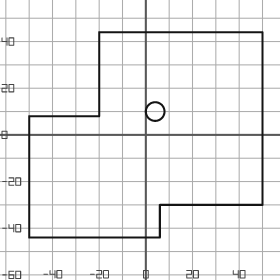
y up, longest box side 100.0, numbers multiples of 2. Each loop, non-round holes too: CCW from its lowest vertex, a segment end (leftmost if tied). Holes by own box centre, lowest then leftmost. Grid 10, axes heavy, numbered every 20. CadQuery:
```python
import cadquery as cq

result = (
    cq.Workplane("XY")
    .moveTo(-50.0, -44.0)
    .lineTo(6.0, -44.0)
    .lineTo(6.0, -30.0)
    .lineTo(50.0, -30.0)
    .lineTo(50.0, 44.0)
    .lineTo(-20.0, 44.0)
    .lineTo(-20.0, 8.0)
    .lineTo(-50.0, 8.0)
    .close()
    .moveTo(4.0, 10.0)
    .circle(4.0)
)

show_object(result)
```